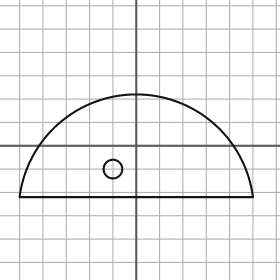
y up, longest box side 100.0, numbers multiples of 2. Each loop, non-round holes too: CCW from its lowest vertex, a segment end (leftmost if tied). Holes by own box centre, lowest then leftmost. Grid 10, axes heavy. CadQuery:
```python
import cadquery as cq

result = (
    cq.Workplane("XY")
    .moveTo(-50.0, -22.0)
    .lineTo(50.0, -22.0)
    .threePointArc((0.0, 22.0), (-50.0, -22.0))
    .close()
    .moveTo(-10.0, -10.0)
    .circle(4.0)
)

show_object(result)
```